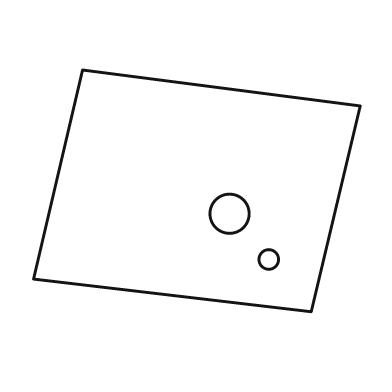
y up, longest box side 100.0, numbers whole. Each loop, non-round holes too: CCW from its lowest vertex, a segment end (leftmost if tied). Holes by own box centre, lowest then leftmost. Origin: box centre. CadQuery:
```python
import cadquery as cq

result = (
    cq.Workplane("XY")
    .moveTo(35.0, -37.0)
    .lineTo(50.0, 26.0)
    .lineTo(-35.0, 37.0)
    .lineTo(-50.0, -27.0)
    .close()
    .moveTo(22.0, -21.0)
    .circle(3.0)
    .moveTo(10.0, -7.0)
    .circle(6.0)
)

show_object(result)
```